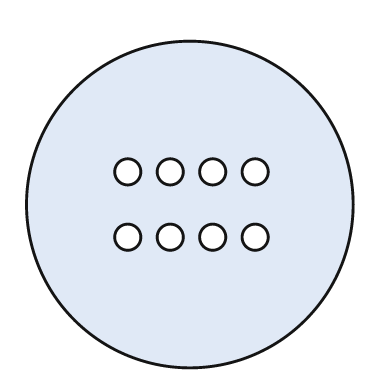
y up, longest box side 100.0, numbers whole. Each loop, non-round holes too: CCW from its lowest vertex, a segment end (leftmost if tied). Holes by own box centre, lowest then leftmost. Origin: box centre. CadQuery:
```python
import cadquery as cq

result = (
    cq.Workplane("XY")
    .moveTo(0.0, 0.0)
    .circle(50.0)
    .moveTo(-19.0, -10.0)
    .circle(4.0)
    .moveTo(-6.0, -10.0)
    .circle(4.0)
    .moveTo(7.0, -10.0)
    .circle(4.0)
    .moveTo(20.0, -10.0)
    .circle(4.0)
    .moveTo(-19.0, 10.0)
    .circle(4.0)
    .moveTo(-6.0, 10.0)
    .circle(4.0)
    .moveTo(7.0, 10.0)
    .circle(4.0)
    .moveTo(20.0, 10.0)
    .circle(4.0)
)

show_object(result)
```